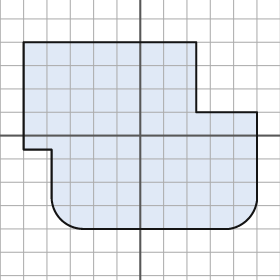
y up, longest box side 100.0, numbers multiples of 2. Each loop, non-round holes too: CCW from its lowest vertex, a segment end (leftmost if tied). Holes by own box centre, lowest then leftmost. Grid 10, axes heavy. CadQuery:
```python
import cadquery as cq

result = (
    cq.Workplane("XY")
    .moveTo(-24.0, -40.0)
    .lineTo(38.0, -40.0)
    .threePointArc((46.0, -36.0), (50.0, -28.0))
    .lineTo(50.0, 10.0)
    .lineTo(24.0, 10.0)
    .lineTo(24.0, 40.0)
    .lineTo(-50.0, 40.0)
    .lineTo(-50.0, -6.0)
    .lineTo(-38.0, -6.0)
    .lineTo(-38.0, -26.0)
    .threePointArc((-34.0, -36.0), (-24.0, -40.0))
    .close()
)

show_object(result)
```